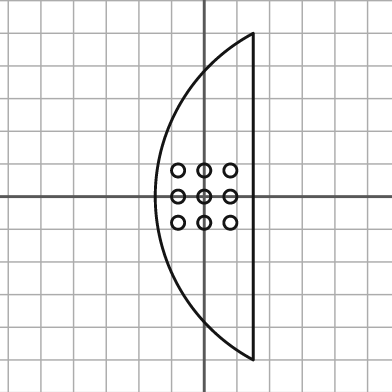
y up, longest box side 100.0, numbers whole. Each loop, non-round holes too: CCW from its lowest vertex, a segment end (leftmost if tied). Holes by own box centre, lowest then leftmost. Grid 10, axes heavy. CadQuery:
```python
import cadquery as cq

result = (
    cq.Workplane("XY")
    .moveTo(15.0, -50.0)
    .lineTo(15.0, 50.0)
    .threePointArc((-15.0, 0.0), (15.0, -50.0))
    .close()
    .moveTo(-8.0, -8.0)
    .circle(2.0)
    .moveTo(0.0, -8.0)
    .circle(2.0)
    .moveTo(8.0, -8.0)
    .circle(2.0)
    .moveTo(-8.0, 0.0)
    .circle(2.0)
    .moveTo(0.0, 0.0)
    .circle(2.0)
    .moveTo(8.0, 0.0)
    .circle(2.0)
    .moveTo(-8.0, 8.0)
    .circle(2.0)
    .moveTo(0.0, 8.0)
    .circle(2.0)
    .moveTo(8.0, 8.0)
    .circle(2.0)
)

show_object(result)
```